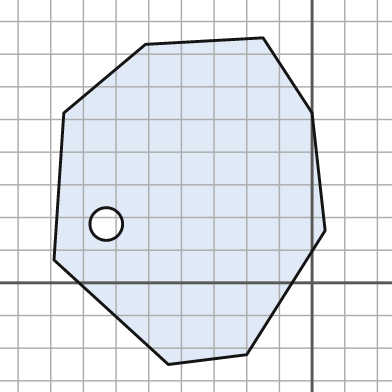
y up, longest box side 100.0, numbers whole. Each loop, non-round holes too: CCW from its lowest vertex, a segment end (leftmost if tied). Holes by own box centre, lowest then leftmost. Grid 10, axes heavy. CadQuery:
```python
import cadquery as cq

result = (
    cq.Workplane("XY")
    .moveTo(-44.0, -25.0)
    .lineTo(-20.0, -22.0)
    .lineTo(4.0, 16.0)
    .lineTo(0.0, 52.0)
    .lineTo(-15.0, 75.0)
    .lineTo(-51.0, 73.0)
    .lineTo(-76.0, 52.0)
    .lineTo(-79.0, 7.0)
    .close()
    .moveTo(-63.0, 18.0)
    .circle(5.0)
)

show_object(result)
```